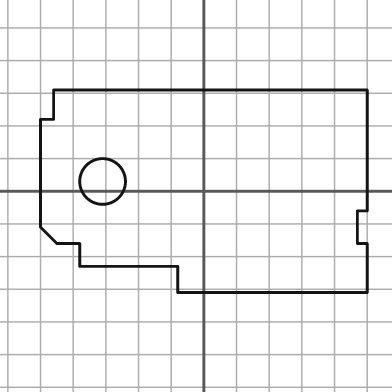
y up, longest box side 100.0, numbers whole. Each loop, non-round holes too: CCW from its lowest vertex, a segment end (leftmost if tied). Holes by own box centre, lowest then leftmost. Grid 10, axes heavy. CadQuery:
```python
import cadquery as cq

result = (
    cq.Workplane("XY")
    .moveTo(-8.0, -31.0)
    .lineTo(50.0, -31.0)
    .lineTo(50.0, -16.0)
    .lineTo(47.0, -16.0)
    .lineTo(47.0, -6.0)
    .lineTo(50.0, -6.0)
    .lineTo(50.0, 31.0)
    .lineTo(-46.0, 31.0)
    .lineTo(-46.0, 22.0)
    .lineTo(-50.0, 22.0)
    .lineTo(-50.0, -11.0)
    .lineTo(-45.0, -16.0)
    .lineTo(-38.0, -16.0)
    .lineTo(-38.0, -23.0)
    .lineTo(-8.0, -23.0)
    .close()
    .moveTo(-31.0, 3.0)
    .circle(7.0)
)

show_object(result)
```